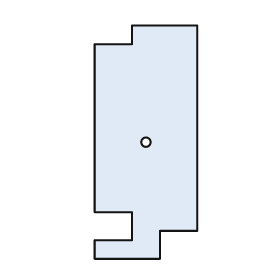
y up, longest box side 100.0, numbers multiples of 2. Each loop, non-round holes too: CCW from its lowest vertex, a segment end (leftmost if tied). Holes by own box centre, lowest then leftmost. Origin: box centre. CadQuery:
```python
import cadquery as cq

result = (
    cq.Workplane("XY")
    .moveTo(-22.0, -50.0)
    .lineTo(6.0, -50.0)
    .lineTo(6.0, -38.0)
    .lineTo(22.0, -38.0)
    .lineTo(22.0, 50.0)
    .lineTo(-6.0, 50.0)
    .lineTo(-6.0, 42.0)
    .lineTo(-22.0, 42.0)
    .lineTo(-22.0, -30.0)
    .lineTo(-6.0, -30.0)
    .lineTo(-6.0, -42.0)
    .lineTo(-22.0, -42.0)
    .close()
    .moveTo(0.0, 0.0)
    .circle(2.0)
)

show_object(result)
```